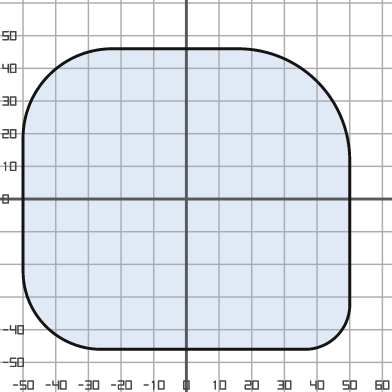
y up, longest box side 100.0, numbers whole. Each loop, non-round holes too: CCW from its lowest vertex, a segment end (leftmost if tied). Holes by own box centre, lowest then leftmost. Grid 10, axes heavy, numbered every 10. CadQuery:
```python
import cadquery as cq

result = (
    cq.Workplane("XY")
    .moveTo(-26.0, -46.0)
    .lineTo(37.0, -46.0)
    .threePointArc((46.0, -42.0), (50.0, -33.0))
    .lineTo(50.0, 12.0)
    .threePointArc((40.0, 36.0), (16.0, 46.0))
    .lineTo(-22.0, 46.0)
    .threePointArc((-42.0, 38.0), (-50.0, 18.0))
    .lineTo(-50.0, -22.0)
    .threePointArc((-43.0, -39.0), (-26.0, -46.0))
    .close()
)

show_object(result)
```